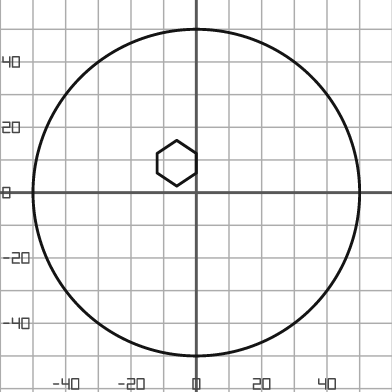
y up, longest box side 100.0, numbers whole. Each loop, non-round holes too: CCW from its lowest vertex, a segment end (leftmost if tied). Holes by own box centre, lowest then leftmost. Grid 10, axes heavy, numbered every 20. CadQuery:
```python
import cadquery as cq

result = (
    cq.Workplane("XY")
    .moveTo(0.0, 0.0)
    .circle(50.0)
    .moveTo(-6.0, 2.0)
    .lineTo(0.0, 6.0)
    .lineTo(0.0, 12.0)
    .lineTo(-6.0, 16.0)
    .lineTo(-12.0, 12.0)
    .lineTo(-12.0, 6.0)
    .close()
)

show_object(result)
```